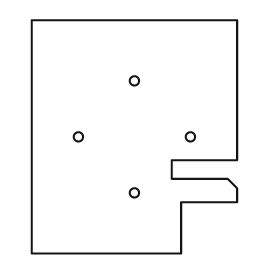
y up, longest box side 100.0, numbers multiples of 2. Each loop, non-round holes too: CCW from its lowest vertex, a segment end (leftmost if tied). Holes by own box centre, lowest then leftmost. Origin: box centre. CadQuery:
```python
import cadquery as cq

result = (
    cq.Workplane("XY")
    .moveTo(-44.0, -50.0)
    .lineTo(20.0, -50.0)
    .lineTo(20.0, -28.0)
    .lineTo(44.0, -28.0)
    .lineTo(44.0, -22.0)
    .lineTo(40.0, -18.0)
    .lineTo(16.0, -18.0)
    .lineTo(16.0, -10.0)
    .lineTo(44.0, -10.0)
    .lineTo(44.0, 50.0)
    .lineTo(-44.0, 50.0)
    .close()
    .moveTo(0.0, -24.0)
    .circle(2.0)
    .moveTo(-24.0, 0.0)
    .circle(2.0)
    .moveTo(24.0, 0.0)
    .circle(2.0)
    .moveTo(0.0, 24.0)
    .circle(2.0)
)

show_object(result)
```